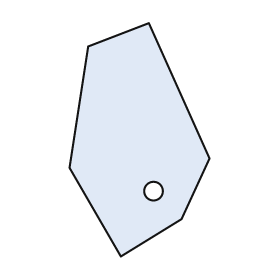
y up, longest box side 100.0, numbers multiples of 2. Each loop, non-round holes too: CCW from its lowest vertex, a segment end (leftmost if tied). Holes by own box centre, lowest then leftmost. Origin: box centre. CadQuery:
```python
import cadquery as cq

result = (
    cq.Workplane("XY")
    .moveTo(-8.0, -50.0)
    .lineTo(18.0, -34.0)
    .lineTo(30.0, -8.0)
    .lineTo(4.0, 50.0)
    .lineTo(-22.0, 40.0)
    .lineTo(-30.0, -12.0)
    .close()
    .moveTo(6.0, -22.0)
    .circle(4.0)
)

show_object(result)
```